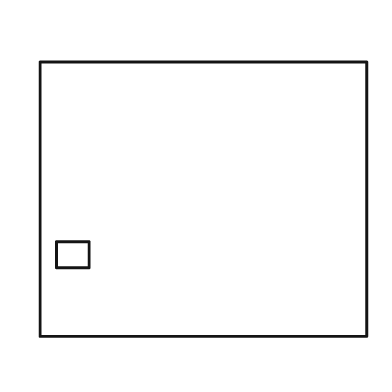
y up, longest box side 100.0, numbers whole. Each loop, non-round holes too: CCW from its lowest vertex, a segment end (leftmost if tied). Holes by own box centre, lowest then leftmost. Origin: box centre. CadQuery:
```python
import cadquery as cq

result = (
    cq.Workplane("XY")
    .moveTo(-50.0, -42.0)
    .lineTo(50.0, -42.0)
    .lineTo(50.0, 42.0)
    .lineTo(-50.0, 42.0)
    .close()
    .moveTo(-45.0, -21.0)
    .lineTo(-35.0, -21.0)
    .lineTo(-35.0, -13.0)
    .lineTo(-45.0, -13.0)
    .close()
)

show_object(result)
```